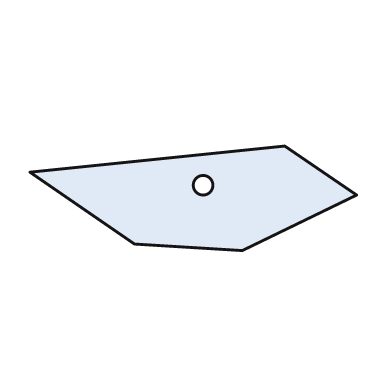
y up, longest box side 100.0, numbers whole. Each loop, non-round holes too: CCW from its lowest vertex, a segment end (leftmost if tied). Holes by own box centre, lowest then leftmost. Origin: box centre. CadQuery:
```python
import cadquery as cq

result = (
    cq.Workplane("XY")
    .moveTo(15.0, -16.0)
    .lineTo(50.0, 1.0)
    .lineTo(28.0, 16.0)
    .lineTo(-50.0, 8.0)
    .lineTo(-18.0, -14.0)
    .close()
    .moveTo(3.0, 4.0)
    .circle(3.0)
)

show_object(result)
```